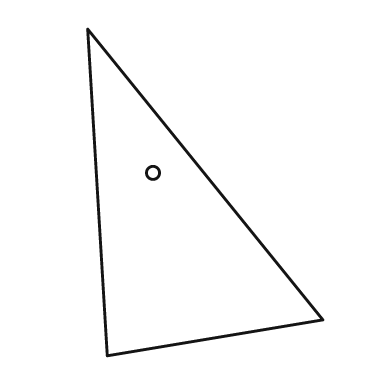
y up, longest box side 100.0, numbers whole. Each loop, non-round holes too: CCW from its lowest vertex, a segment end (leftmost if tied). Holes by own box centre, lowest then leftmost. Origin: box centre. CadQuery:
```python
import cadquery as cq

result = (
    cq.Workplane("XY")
    .moveTo(-30.0, -50.0)
    .lineTo(36.0, -39.0)
    .lineTo(-36.0, 50.0)
    .close()
    .moveTo(-16.0, 6.0)
    .circle(2.0)
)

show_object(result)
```